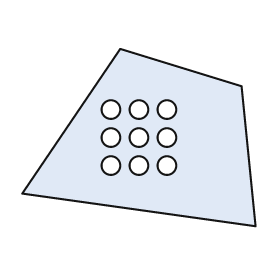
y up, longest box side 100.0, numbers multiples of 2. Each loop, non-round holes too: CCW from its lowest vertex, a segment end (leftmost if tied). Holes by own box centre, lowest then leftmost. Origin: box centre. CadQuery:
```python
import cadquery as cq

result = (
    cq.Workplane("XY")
    .moveTo(50.0, -38.0)
    .lineTo(44.0, 22.0)
    .lineTo(-8.0, 38.0)
    .lineTo(-50.0, -24.0)
    .close()
    .moveTo(-12.0, -12.0)
    .circle(4.0)
    .moveTo(0.0, -12.0)
    .circle(4.0)
    .moveTo(12.0, -12.0)
    .circle(4.0)
    .moveTo(-12.0, 0.0)
    .circle(4.0)
    .moveTo(0.0, 0.0)
    .circle(4.0)
    .moveTo(12.0, 0.0)
    .circle(4.0)
    .moveTo(-12.0, 12.0)
    .circle(4.0)
    .moveTo(0.0, 12.0)
    .circle(4.0)
    .moveTo(12.0, 12.0)
    .circle(4.0)
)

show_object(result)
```